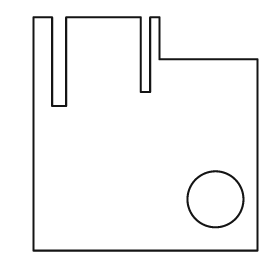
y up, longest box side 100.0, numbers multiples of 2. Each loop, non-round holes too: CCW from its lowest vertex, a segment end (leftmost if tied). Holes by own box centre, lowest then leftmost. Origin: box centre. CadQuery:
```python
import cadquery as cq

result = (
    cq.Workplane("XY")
    .moveTo(-48.0, -50.0)
    .lineTo(48.0, -50.0)
    .lineTo(48.0, 32.0)
    .lineTo(6.0, 32.0)
    .lineTo(6.0, 50.0)
    .lineTo(2.0, 50.0)
    .lineTo(2.0, 18.0)
    .lineTo(-2.0, 18.0)
    .lineTo(-2.0, 50.0)
    .lineTo(-34.0, 50.0)
    .lineTo(-34.0, 12.0)
    .lineTo(-40.0, 12.0)
    .lineTo(-40.0, 50.0)
    .lineTo(-48.0, 50.0)
    .close()
    .moveTo(30.0, -28.0)
    .circle(12.0)
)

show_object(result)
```